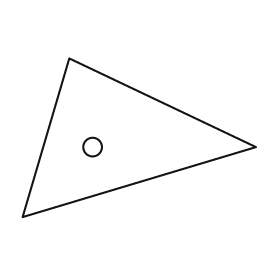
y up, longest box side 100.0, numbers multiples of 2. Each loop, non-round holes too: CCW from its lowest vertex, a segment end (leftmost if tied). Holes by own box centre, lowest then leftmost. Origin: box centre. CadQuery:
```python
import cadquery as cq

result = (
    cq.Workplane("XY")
    .moveTo(-50.0, -34.0)
    .lineTo(50.0, -4.0)
    .lineTo(-30.0, 34.0)
    .close()
    .moveTo(-20.0, -4.0)
    .circle(4.0)
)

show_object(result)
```